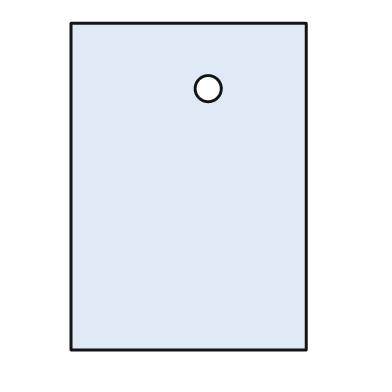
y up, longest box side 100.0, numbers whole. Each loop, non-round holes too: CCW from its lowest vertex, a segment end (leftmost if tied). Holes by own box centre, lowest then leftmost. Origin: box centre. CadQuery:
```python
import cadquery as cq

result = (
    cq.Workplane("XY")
    .moveTo(-36.0, -50.0)
    .lineTo(36.0, -50.0)
    .lineTo(36.0, 50.0)
    .lineTo(-36.0, 50.0)
    .close()
    .moveTo(6.0, 30.0)
    .circle(4.0)
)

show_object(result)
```